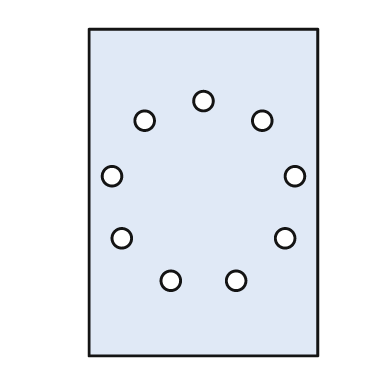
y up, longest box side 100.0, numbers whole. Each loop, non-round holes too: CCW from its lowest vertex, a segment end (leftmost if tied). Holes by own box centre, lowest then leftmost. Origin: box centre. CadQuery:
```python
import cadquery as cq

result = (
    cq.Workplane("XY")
    .moveTo(-35.0, -50.0)
    .lineTo(35.0, -50.0)
    .lineTo(35.0, 50.0)
    .lineTo(-35.0, 50.0)
    .close()
    .moveTo(-10.0, -27.0)
    .circle(3.0)
    .moveTo(10.0, -27.0)
    .circle(3.0)
    .moveTo(-25.0, -14.0)
    .circle(3.0)
    .moveTo(25.0, -14.0)
    .circle(3.0)
    .moveTo(-28.0, 5.0)
    .circle(3.0)
    .moveTo(28.0, 5.0)
    .circle(3.0)
    .moveTo(-18.0, 22.0)
    .circle(3.0)
    .moveTo(18.0, 22.0)
    .circle(3.0)
    .moveTo(0.0, 28.0)
    .circle(3.0)
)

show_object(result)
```